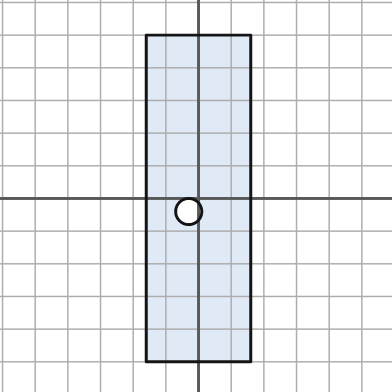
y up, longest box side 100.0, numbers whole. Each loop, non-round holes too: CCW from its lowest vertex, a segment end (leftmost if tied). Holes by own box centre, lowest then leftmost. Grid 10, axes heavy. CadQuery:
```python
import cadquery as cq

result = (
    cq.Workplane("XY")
    .moveTo(-16.0, -50.0)
    .lineTo(16.0, -50.0)
    .lineTo(16.0, 50.0)
    .lineTo(-16.0, 50.0)
    .close()
    .moveTo(-3.0, -4.0)
    .circle(4.0)
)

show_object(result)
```